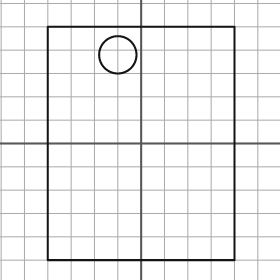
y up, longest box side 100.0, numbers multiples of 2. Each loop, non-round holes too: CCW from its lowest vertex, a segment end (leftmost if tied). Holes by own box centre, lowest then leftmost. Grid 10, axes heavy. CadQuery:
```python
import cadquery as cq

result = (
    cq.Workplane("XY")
    .moveTo(-40.0, -50.0)
    .lineTo(40.0, -50.0)
    .lineTo(40.0, 50.0)
    .lineTo(-40.0, 50.0)
    .close()
    .moveTo(-10.0, 38.0)
    .circle(8.0)
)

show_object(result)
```